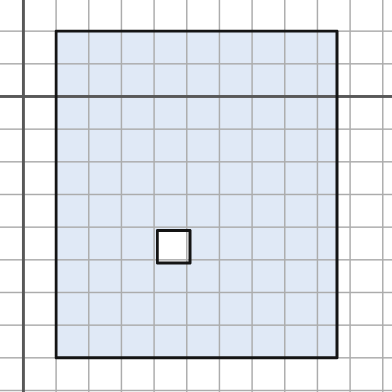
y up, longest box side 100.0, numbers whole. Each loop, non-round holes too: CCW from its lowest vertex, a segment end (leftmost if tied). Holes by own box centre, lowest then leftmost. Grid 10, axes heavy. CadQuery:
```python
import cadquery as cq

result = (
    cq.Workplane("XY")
    .moveTo(10.0, -80.0)
    .lineTo(96.0, -80.0)
    .lineTo(96.0, 20.0)
    .lineTo(10.0, 20.0)
    .close()
    .moveTo(41.0, -51.0)
    .lineTo(51.0, -51.0)
    .lineTo(51.0, -41.0)
    .lineTo(41.0, -41.0)
    .close()
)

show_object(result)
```